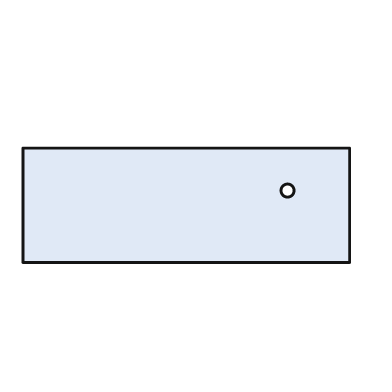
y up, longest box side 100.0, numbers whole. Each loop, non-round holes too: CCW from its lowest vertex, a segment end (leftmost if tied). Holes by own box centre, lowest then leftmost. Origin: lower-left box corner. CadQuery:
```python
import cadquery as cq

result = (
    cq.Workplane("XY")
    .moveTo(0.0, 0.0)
    .lineTo(100.0, 0.0)
    .lineTo(100.0, 35.0)
    .lineTo(0.0, 35.0)
    .close()
    .moveTo(81.0, 22.0)
    .circle(2.0)
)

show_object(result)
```